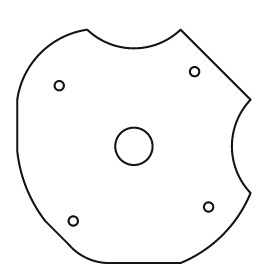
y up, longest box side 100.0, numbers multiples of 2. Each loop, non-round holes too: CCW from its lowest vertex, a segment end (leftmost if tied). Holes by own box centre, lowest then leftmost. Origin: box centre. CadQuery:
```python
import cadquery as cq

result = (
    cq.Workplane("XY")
    .moveTo(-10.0, -50.0)
    .lineTo(20.0, -50.0)
    .threePointArc((38.0, -38.0), (50.0, -20.0))
    .threePointArc((42.0, 0.0), (50.0, 20.0))
    .lineTo(20.0, 50.0)
    .threePointArc((0.0, 42.0), (-20.0, 50.0))
    .threePointArc((-40.0, 40.0), (-50.0, 20.0))
    .lineTo(-50.0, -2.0)
    .threePointArc((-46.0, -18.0), (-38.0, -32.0))
    .lineTo(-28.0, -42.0)
    .threePointArc((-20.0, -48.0), (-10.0, -50.0))
    .close()
    .moveTo(-26.0, -32.0)
    .circle(2.0)
    .moveTo(32.0, -26.0)
    .circle(2.0)
    .moveTo(0.0, 0.0)
    .circle(8.0)
    .moveTo(-32.0, 26.0)
    .circle(2.0)
    .moveTo(26.0, 32.0)
    .circle(2.0)
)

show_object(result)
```